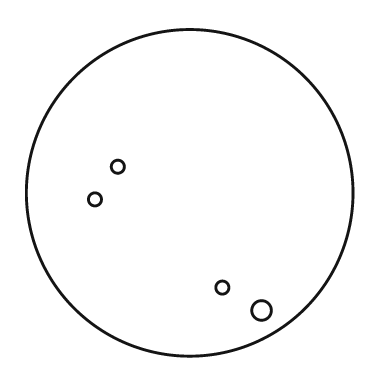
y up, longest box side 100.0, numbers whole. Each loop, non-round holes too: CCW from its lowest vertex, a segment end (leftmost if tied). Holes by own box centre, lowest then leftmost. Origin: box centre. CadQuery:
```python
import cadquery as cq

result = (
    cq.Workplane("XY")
    .moveTo(0.0, 0.0)
    .circle(50.0)
    .moveTo(22.0, -36.0)
    .circle(3.0)
    .moveTo(10.0, -29.0)
    .circle(2.0)
    .moveTo(-29.0, -2.0)
    .circle(2.0)
    .moveTo(-22.0, 8.0)
    .circle(2.0)
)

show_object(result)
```